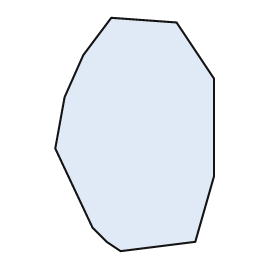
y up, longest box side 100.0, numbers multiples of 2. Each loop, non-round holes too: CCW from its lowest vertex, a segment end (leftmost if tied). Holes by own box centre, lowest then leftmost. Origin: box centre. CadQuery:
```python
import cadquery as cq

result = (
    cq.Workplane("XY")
    .moveTo(-6.0, -50.0)
    .lineTo(26.0, -46.0)
    .lineTo(34.0, -18.0)
    .lineTo(34.0, 24.0)
    .lineTo(18.0, 48.0)
    .lineTo(-10.0, 50.0)
    .lineTo(-22.0, 34.0)
    .lineTo(-30.0, 16.0)
    .lineTo(-34.0, -6.0)
    .lineTo(-18.0, -40.0)
    .lineTo(-12.0, -46.0)
    .close()
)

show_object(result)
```